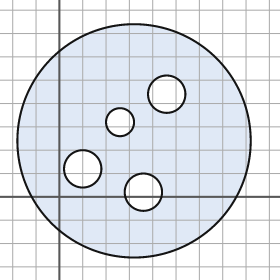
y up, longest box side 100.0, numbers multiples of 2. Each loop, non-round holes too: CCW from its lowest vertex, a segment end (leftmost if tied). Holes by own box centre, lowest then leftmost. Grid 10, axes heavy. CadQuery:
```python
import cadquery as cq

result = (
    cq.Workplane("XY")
    .moveTo(32.0, 24.0)
    .circle(50.0)
    .moveTo(36.0, 2.0)
    .circle(8.0)
    .moveTo(10.0, 12.0)
    .circle(8.0)
    .moveTo(26.0, 32.0)
    .circle(6.0)
    .moveTo(46.0, 44.0)
    .circle(8.0)
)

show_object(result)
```